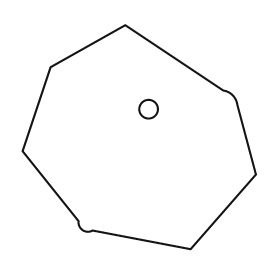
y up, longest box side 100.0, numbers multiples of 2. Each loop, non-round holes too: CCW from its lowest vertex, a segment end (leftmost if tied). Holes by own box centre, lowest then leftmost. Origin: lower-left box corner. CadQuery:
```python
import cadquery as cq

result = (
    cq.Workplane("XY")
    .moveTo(72.0, 0.0)
    .lineTo(100.0, 32.0)
    .lineTo(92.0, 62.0)
    .threePointArc((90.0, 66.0), (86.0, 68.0))
    .lineTo(44.0, 96.0)
    .lineTo(12.0, 78.0)
    .lineTo(0.0, 42.0)
    .lineTo(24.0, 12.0)
    .threePointArc((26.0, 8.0), (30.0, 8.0))
    .close()
    .moveTo(54.0, 60.0)
    .circle(4.0)
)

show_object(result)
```